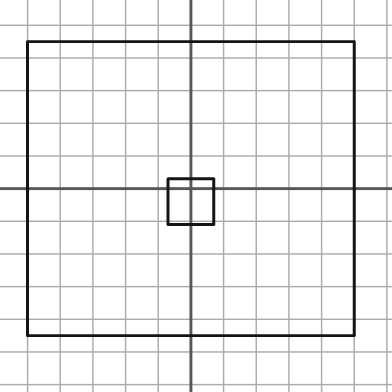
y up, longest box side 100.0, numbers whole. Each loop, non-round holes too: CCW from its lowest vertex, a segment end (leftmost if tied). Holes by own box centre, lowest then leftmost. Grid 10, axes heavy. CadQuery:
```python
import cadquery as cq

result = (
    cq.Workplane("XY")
    .moveTo(-50.0, -45.0)
    .lineTo(50.0, -45.0)
    .lineTo(50.0, 45.0)
    .lineTo(-50.0, 45.0)
    .close()
    .moveTo(-7.0, -11.0)
    .lineTo(7.0, -11.0)
    .lineTo(7.0, 3.0)
    .lineTo(-7.0, 3.0)
    .close()
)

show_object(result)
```